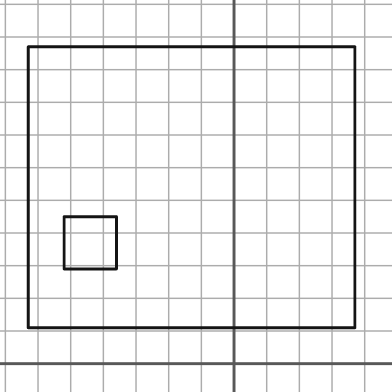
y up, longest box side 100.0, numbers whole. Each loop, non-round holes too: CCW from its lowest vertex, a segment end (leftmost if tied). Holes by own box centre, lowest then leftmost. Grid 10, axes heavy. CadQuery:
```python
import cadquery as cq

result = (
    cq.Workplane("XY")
    .moveTo(-63.0, 11.0)
    .lineTo(37.0, 11.0)
    .lineTo(37.0, 97.0)
    .lineTo(-63.0, 97.0)
    .close()
    .moveTo(-52.0, 29.0)
    .lineTo(-36.0, 29.0)
    .lineTo(-36.0, 45.0)
    .lineTo(-52.0, 45.0)
    .close()
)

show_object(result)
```